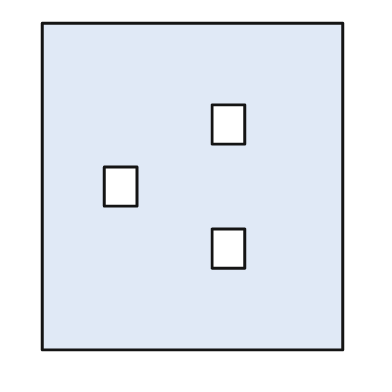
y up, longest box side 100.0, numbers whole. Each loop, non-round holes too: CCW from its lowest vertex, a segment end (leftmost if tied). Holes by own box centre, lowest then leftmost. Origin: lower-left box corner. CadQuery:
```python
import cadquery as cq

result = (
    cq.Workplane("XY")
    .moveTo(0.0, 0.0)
    .lineTo(92.0, 0.0)
    .lineTo(92.0, 100.0)
    .lineTo(0.0, 100.0)
    .close()
    .moveTo(52.0, 25.0)
    .lineTo(62.0, 25.0)
    .lineTo(62.0, 37.0)
    .lineTo(52.0, 37.0)
    .close()
    .moveTo(19.0, 44.0)
    .lineTo(29.0, 44.0)
    .lineTo(29.0, 56.0)
    .lineTo(19.0, 56.0)
    .close()
    .moveTo(52.0, 63.0)
    .lineTo(62.0, 63.0)
    .lineTo(62.0, 75.0)
    .lineTo(52.0, 75.0)
    .close()
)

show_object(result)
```